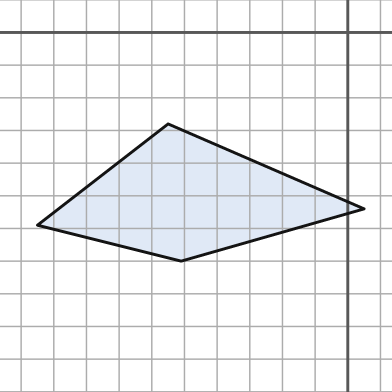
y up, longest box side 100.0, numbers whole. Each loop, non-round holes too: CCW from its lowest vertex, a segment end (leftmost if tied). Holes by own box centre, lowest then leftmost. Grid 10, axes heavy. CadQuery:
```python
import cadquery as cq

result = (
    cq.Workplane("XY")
    .moveTo(-51.0, -70.0)
    .lineTo(5.0, -54.0)
    .lineTo(-55.0, -28.0)
    .lineTo(-95.0, -59.0)
    .close()
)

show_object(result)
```